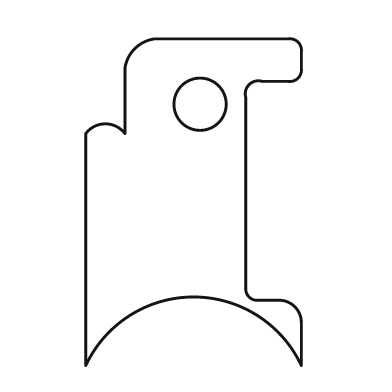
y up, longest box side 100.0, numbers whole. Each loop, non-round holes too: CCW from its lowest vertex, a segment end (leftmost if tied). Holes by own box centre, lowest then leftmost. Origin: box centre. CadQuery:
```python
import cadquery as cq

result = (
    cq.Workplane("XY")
    .moveTo(-33.0, -50.0)
    .threePointArc((0.0, -29.0), (33.0, -50.0))
    .lineTo(33.0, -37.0)
    .threePointArc((31.0, -32.0), (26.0, -30.0))
    .lineTo(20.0, -30.0)
    .threePointArc((17.0, -29.0), (16.0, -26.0))
    .lineTo(16.0, 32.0)
    .threePointArc((17.0, 36.0), (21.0, 37.0))
    .lineTo(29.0, 37.0)
    .threePointArc((32.0, 38.0), (33.0, 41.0))
    .lineTo(33.0, 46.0)
    .threePointArc((32.0, 49.0), (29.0, 50.0))
    .lineTo(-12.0, 50.0)
    .threePointArc((-18.0, 47.0), (-21.0, 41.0))
    .lineTo(-21.0, 21.0)
    .threePointArc((-27.0, 24.0), (-33.0, 21.0))
    .close()
    .moveTo(2.0, 30.0)
    .circle(8.0)
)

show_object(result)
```